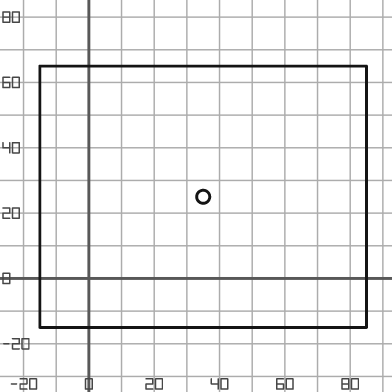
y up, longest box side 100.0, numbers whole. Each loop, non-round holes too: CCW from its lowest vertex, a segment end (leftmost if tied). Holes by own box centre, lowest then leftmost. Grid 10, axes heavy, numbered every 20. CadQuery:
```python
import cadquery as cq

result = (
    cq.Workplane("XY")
    .moveTo(-15.0, -15.0)
    .lineTo(85.0, -15.0)
    .lineTo(85.0, 65.0)
    .lineTo(-15.0, 65.0)
    .close()
    .moveTo(35.0, 25.0)
    .circle(2.0)
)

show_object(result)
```